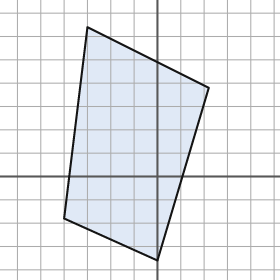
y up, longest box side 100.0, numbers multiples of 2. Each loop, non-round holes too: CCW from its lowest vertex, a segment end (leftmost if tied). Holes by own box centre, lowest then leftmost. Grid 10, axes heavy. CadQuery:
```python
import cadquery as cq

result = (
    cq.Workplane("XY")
    .moveTo(0.0, -36.0)
    .lineTo(22.0, 38.0)
    .lineTo(-30.0, 64.0)
    .lineTo(-40.0, -18.0)
    .close()
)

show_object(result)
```